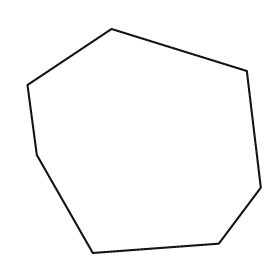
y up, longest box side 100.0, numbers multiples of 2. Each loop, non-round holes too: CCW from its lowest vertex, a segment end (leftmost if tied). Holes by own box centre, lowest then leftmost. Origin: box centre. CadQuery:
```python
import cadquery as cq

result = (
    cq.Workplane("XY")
    .moveTo(-22.0, -48.0)
    .lineTo(32.0, -44.0)
    .lineTo(50.0, -20.0)
    .lineTo(44.0, 30.0)
    .lineTo(-14.0, 48.0)
    .lineTo(-50.0, 24.0)
    .lineTo(-46.0, -6.0)
    .close()
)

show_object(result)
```